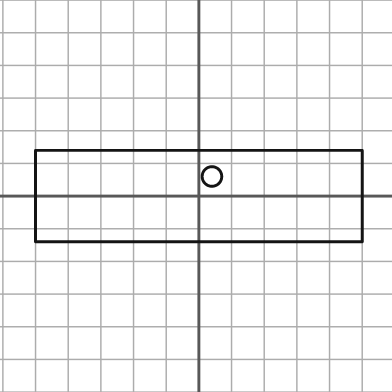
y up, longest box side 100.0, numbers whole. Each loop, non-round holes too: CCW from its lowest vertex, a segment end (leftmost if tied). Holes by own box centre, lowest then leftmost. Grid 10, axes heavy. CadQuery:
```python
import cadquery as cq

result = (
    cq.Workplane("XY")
    .moveTo(-50.0, -14.0)
    .lineTo(50.0, -14.0)
    .lineTo(50.0, 14.0)
    .lineTo(-50.0, 14.0)
    .close()
    .moveTo(4.0, 6.0)
    .circle(3.0)
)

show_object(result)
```